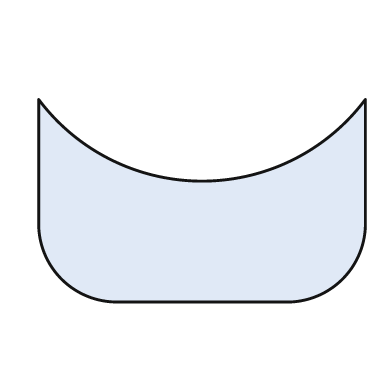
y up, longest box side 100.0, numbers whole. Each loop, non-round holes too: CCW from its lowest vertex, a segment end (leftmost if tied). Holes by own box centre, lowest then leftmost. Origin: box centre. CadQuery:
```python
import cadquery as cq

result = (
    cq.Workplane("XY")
    .moveTo(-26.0, -31.0)
    .lineTo(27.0, -31.0)
    .threePointArc((43.0, -24.0), (50.0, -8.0))
    .lineTo(50.0, 31.0)
    .threePointArc((0.0, 6.0), (-50.0, 31.0))
    .lineTo(-50.0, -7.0)
    .threePointArc((-43.0, -24.0), (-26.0, -31.0))
    .close()
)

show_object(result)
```